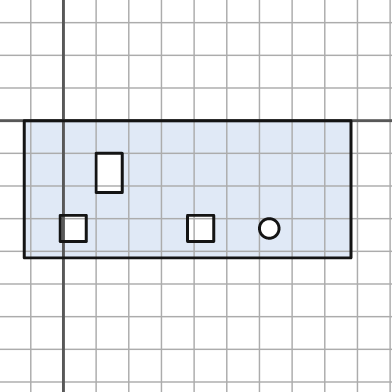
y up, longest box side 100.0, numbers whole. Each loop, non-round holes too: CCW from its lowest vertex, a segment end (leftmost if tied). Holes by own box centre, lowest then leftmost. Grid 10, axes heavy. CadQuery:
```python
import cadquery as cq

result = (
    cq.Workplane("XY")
    .moveTo(-12.0, -42.0)
    .lineTo(88.0, -42.0)
    .lineTo(88.0, 0.0)
    .lineTo(-12.0, 0.0)
    .close()
    .moveTo(-1.0, -37.0)
    .lineTo(7.0, -37.0)
    .lineTo(7.0, -29.0)
    .lineTo(-1.0, -29.0)
    .close()
    .moveTo(38.0, -37.0)
    .lineTo(46.0, -37.0)
    .lineTo(46.0, -29.0)
    .lineTo(38.0, -29.0)
    .close()
    .moveTo(63.0, -33.0)
    .circle(3.0)
    .moveTo(10.0, -22.0)
    .lineTo(18.0, -22.0)
    .lineTo(18.0, -10.0)
    .lineTo(10.0, -10.0)
    .close()
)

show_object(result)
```